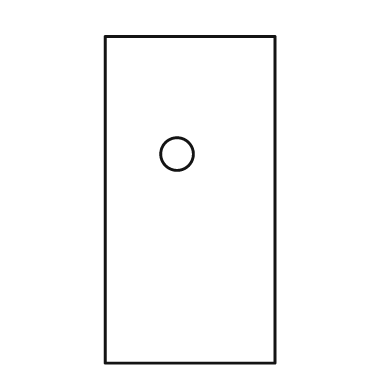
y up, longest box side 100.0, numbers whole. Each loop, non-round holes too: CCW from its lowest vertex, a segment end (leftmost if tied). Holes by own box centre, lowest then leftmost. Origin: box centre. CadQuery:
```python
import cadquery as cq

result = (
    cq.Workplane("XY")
    .moveTo(-26.0, -50.0)
    .lineTo(26.0, -50.0)
    .lineTo(26.0, 50.0)
    .lineTo(-26.0, 50.0)
    .close()
    .moveTo(-4.0, 14.0)
    .circle(5.0)
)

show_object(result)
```